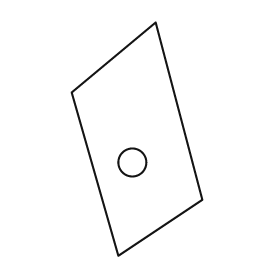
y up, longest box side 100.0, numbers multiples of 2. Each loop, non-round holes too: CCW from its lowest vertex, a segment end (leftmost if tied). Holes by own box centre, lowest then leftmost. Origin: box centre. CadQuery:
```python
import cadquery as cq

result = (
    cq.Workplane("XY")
    .moveTo(-8.0, -50.0)
    .lineTo(28.0, -26.0)
    .lineTo(8.0, 50.0)
    .lineTo(-28.0, 20.0)
    .close()
    .moveTo(-2.0, -10.0)
    .circle(6.0)
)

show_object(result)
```